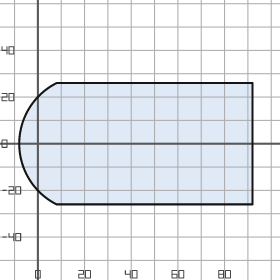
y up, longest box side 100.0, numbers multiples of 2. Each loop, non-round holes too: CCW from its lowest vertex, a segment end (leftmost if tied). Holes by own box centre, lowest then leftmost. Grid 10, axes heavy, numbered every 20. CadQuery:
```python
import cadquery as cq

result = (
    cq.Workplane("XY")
    .moveTo(8.0, -26.0)
    .lineTo(92.0, -26.0)
    .lineTo(92.0, 26.0)
    .lineTo(8.0, 26.0)
    .threePointArc((-8.0, 0.0), (8.0, -26.0))
    .close()
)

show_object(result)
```